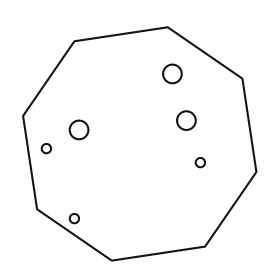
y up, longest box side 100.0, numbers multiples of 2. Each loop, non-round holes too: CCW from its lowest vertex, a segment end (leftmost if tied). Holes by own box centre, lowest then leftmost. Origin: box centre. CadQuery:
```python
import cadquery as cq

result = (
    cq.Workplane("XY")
    .moveTo(-12.0, -50.0)
    .lineTo(28.0, -44.0)
    .lineTo(50.0, -12.0)
    .lineTo(44.0, 28.0)
    .lineTo(12.0, 50.0)
    .lineTo(-28.0, 44.0)
    .lineTo(-50.0, 12.0)
    .lineTo(-44.0, -28.0)
    .close()
    .moveTo(-28.0, -32.0)
    .circle(2.0)
    .moveTo(26.0, -8.0)
    .circle(2.0)
    .moveTo(-40.0, -2.0)
    .circle(2.0)
    .moveTo(-26.0, 6.0)
    .circle(4.0)
    .moveTo(20.0, 10.0)
    .circle(4.0)
    .moveTo(14.0, 30.0)
    .circle(4.0)
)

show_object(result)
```